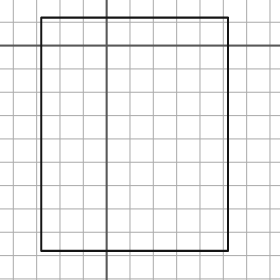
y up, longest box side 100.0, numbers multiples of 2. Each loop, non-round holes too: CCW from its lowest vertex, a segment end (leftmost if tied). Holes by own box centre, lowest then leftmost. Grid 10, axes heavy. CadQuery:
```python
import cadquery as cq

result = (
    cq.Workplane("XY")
    .moveTo(-28.0, -88.0)
    .lineTo(52.0, -88.0)
    .lineTo(52.0, 12.0)
    .lineTo(-28.0, 12.0)
    .close()
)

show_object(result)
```